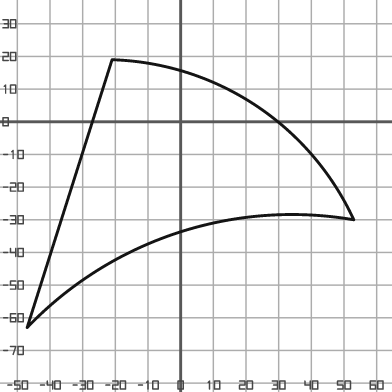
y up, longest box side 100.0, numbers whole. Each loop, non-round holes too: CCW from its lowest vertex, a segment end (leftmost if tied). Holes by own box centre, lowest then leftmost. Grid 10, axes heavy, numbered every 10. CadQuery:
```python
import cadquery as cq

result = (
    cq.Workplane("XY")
    .moveTo(-47.0, -63.0)
    .threePointArc((-1.0, -34.0), (53.0, -30.0))
    .threePointArc((23.0, 5.0), (-21.0, 19.0))
    .close()
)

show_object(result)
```